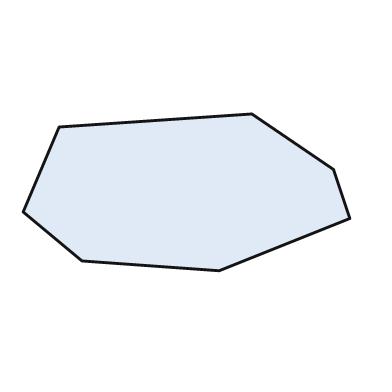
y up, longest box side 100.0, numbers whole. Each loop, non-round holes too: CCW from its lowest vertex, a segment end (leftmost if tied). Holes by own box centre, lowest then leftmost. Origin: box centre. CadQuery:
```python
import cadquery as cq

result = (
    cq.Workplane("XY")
    .moveTo(10.0, -24.0)
    .lineTo(50.0, -8.0)
    .lineTo(45.0, 7.0)
    .lineTo(20.0, 24.0)
    .lineTo(-39.0, 20.0)
    .lineTo(-50.0, -6.0)
    .lineTo(-32.0, -21.0)
    .close()
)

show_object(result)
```